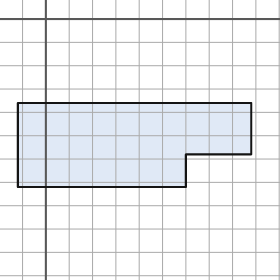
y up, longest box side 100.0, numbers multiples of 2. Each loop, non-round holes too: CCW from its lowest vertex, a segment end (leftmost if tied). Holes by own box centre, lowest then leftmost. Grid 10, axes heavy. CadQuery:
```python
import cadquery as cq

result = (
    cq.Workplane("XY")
    .moveTo(-12.0, -72.0)
    .lineTo(60.0, -72.0)
    .lineTo(60.0, -58.0)
    .lineTo(88.0, -58.0)
    .lineTo(88.0, -36.0)
    .lineTo(-12.0, -36.0)
    .close()
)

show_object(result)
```